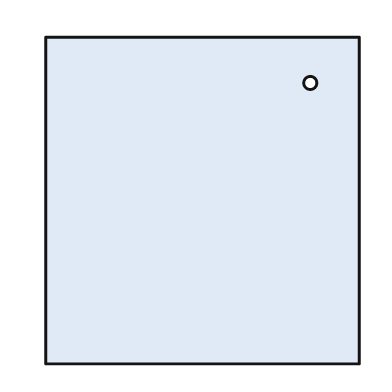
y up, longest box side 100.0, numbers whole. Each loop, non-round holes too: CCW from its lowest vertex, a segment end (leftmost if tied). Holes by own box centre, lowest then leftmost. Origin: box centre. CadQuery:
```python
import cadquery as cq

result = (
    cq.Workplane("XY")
    .moveTo(-48.0, -50.0)
    .lineTo(48.0, -50.0)
    .lineTo(48.0, 50.0)
    .lineTo(-48.0, 50.0)
    .close()
    .moveTo(33.0, 36.0)
    .circle(2.0)
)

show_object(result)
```